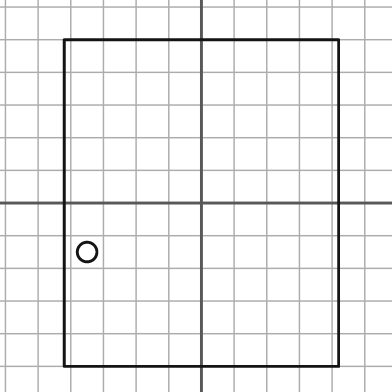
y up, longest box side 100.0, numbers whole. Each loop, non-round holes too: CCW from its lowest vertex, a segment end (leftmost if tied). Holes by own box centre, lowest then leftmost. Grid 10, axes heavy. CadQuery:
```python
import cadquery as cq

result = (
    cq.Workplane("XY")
    .moveTo(-42.0, -50.0)
    .lineTo(42.0, -50.0)
    .lineTo(42.0, 50.0)
    .lineTo(-42.0, 50.0)
    .close()
    .moveTo(-35.0, -15.0)
    .circle(3.0)
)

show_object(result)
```